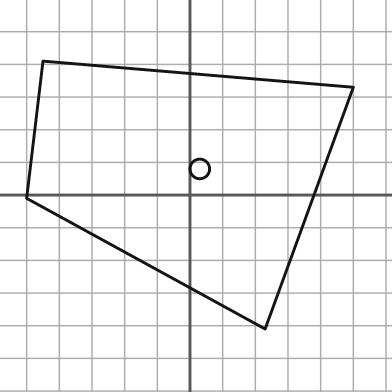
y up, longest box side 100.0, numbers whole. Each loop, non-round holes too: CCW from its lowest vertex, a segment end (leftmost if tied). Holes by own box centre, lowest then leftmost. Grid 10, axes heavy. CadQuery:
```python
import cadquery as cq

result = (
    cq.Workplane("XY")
    .moveTo(23.0, -41.0)
    .lineTo(50.0, 33.0)
    .lineTo(-45.0, 41.0)
    .lineTo(-50.0, -1.0)
    .close()
    .moveTo(3.0, 8.0)
    .circle(3.0)
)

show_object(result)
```